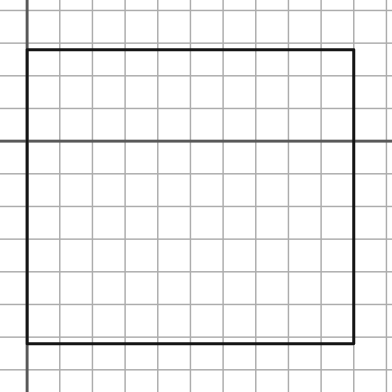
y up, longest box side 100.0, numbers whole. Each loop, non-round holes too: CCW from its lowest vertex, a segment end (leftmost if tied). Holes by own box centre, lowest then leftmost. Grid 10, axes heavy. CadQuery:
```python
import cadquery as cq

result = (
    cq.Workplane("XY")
    .moveTo(0.0, -62.0)
    .lineTo(100.0, -62.0)
    .lineTo(100.0, 28.0)
    .lineTo(0.0, 28.0)
    .close()
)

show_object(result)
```